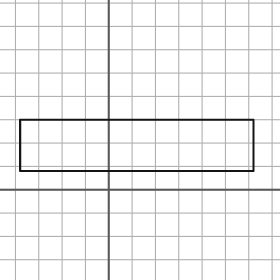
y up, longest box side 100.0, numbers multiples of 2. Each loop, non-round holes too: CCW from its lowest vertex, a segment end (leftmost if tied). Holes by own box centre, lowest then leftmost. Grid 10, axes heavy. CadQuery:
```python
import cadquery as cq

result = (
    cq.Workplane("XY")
    .moveTo(-38.0, 8.0)
    .lineTo(62.0, 8.0)
    .lineTo(62.0, 30.0)
    .lineTo(-38.0, 30.0)
    .close()
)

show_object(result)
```